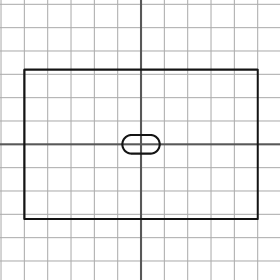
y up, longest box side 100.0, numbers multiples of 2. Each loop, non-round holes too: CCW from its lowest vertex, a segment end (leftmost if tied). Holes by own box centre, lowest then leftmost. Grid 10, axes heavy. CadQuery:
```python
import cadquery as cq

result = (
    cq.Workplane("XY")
    .moveTo(-50.0, -32.0)
    .lineTo(50.0, -32.0)
    .lineTo(50.0, 32.0)
    .lineTo(-50.0, 32.0)
    .close()
    .moveTo(-4.0, -4.0)
    .lineTo(4.0, -4.0)
    .threePointArc((8.0, 0.0), (4.0, 4.0))
    .lineTo(-4.0, 4.0)
    .threePointArc((-8.0, 0.0), (-4.0, -4.0))
    .close()
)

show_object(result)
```